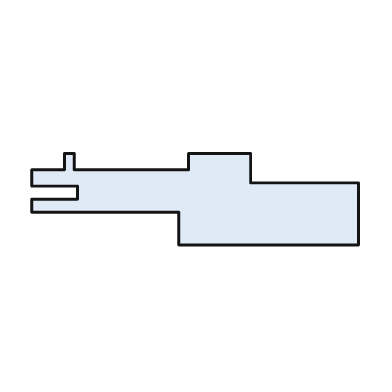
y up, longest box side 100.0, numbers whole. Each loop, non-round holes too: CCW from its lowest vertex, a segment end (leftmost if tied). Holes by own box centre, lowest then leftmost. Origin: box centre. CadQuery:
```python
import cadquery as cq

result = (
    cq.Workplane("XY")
    .moveTo(-5.0, -14.0)
    .lineTo(50.0, -14.0)
    .lineTo(50.0, 5.0)
    .lineTo(17.0, 5.0)
    .lineTo(17.0, 14.0)
    .lineTo(-2.0, 14.0)
    .lineTo(-2.0, 9.0)
    .lineTo(-37.0, 9.0)
    .lineTo(-37.0, 14.0)
    .lineTo(-40.0, 14.0)
    .lineTo(-40.0, 9.0)
    .lineTo(-50.0, 9.0)
    .lineTo(-50.0, 4.0)
    .lineTo(-36.0, 4.0)
    .lineTo(-36.0, 0.0)
    .lineTo(-50.0, 0.0)
    .lineTo(-50.0, -4.0)
    .lineTo(-5.0, -4.0)
    .close()
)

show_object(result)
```